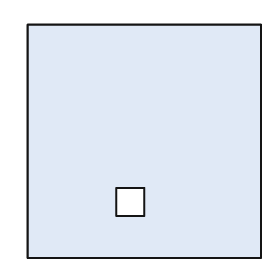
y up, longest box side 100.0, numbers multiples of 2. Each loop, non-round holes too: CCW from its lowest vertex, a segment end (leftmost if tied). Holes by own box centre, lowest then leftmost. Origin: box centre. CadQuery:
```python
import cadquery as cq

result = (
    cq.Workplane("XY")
    .moveTo(-50.0, -50.0)
    .lineTo(50.0, -50.0)
    .lineTo(50.0, 50.0)
    .lineTo(-50.0, 50.0)
    .close()
    .moveTo(-12.0, -32.0)
    .lineTo(0.0, -32.0)
    .lineTo(0.0, -20.0)
    .lineTo(-12.0, -20.0)
    .close()
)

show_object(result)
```